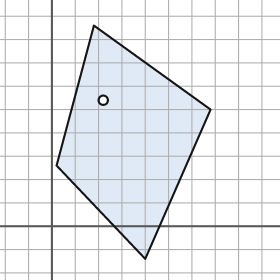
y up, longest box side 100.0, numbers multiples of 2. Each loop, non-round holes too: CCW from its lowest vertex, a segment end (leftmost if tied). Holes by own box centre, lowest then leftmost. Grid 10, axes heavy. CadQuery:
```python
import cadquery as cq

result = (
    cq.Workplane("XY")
    .moveTo(40.0, -14.0)
    .lineTo(68.0, 50.0)
    .lineTo(18.0, 86.0)
    .lineTo(2.0, 26.0)
    .close()
    .moveTo(22.0, 54.0)
    .circle(2.0)
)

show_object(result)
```